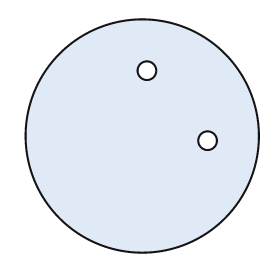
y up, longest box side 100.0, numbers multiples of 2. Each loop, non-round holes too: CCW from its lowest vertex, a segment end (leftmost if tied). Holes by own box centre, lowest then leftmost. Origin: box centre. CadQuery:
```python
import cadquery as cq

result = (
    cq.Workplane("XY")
    .moveTo(0.0, 0.0)
    .circle(50.0)
    .moveTo(28.0, -2.0)
    .circle(4.0)
    .moveTo(2.0, 28.0)
    .circle(4.0)
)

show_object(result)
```